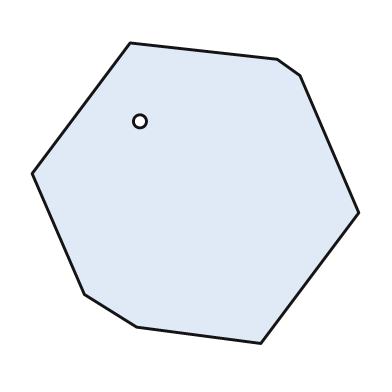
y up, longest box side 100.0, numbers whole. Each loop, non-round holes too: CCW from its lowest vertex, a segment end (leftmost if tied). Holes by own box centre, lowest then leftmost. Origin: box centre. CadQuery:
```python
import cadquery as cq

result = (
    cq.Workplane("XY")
    .moveTo(20.0, -46.0)
    .lineTo(50.0, -6.0)
    .lineTo(32.0, 36.0)
    .lineTo(25.0, 41.0)
    .lineTo(-20.0, 46.0)
    .lineTo(-50.0, 6.0)
    .lineTo(-34.0, -31.0)
    .lineTo(-18.0, -41.0)
    .close()
    .moveTo(-17.0, 22.0)
    .circle(2.0)
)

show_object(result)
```